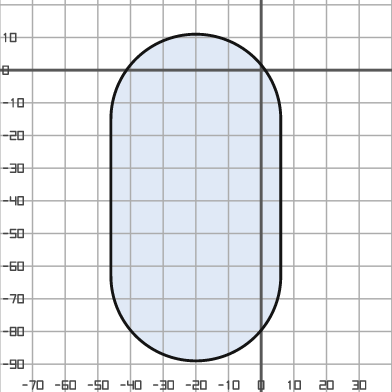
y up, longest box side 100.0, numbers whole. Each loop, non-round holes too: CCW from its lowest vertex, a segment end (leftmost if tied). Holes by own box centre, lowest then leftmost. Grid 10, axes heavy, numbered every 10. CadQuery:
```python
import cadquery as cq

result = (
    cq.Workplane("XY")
    .moveTo(-46.0, -63.0)
    .threePointArc((-20.0, -89.0), (6.0, -63.0))
    .lineTo(6.0, -15.0)
    .threePointArc((-20.0, 11.0), (-46.0, -15.0))
    .close()
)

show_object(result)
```